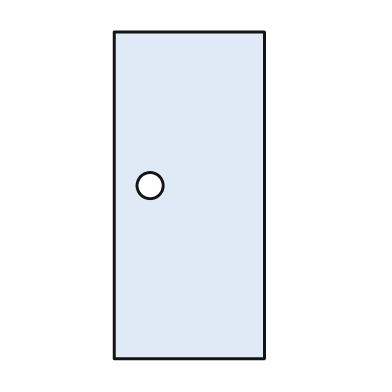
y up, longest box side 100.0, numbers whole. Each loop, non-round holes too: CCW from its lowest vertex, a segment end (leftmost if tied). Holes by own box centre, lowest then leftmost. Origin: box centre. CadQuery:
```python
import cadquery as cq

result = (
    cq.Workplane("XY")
    .moveTo(-23.0, -50.0)
    .lineTo(23.0, -50.0)
    .lineTo(23.0, 50.0)
    .lineTo(-23.0, 50.0)
    .close()
    .moveTo(-12.0, 3.0)
    .circle(4.0)
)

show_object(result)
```